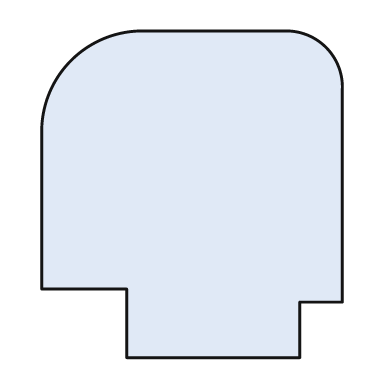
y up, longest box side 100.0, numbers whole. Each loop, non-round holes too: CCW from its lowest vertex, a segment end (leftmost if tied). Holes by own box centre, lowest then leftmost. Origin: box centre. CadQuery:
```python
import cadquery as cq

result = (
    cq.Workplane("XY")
    .moveTo(-20.0, -50.0)
    .lineTo(33.0, -50.0)
    .lineTo(33.0, -33.0)
    .lineTo(46.0, -33.0)
    .lineTo(46.0, 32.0)
    .threePointArc((41.0, 45.0), (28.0, 50.0))
    .lineTo(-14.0, 50.0)
    .threePointArc((-37.0, 41.0), (-46.0, 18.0))
    .lineTo(-46.0, -29.0)
    .lineTo(-20.0, -29.0)
    .close()
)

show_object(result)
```